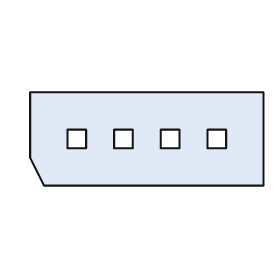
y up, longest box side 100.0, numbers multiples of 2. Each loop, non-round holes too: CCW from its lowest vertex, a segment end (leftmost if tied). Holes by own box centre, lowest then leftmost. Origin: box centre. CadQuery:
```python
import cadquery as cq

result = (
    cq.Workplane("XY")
    .moveTo(-44.0, -20.0)
    .lineTo(50.0, -20.0)
    .lineTo(50.0, 20.0)
    .lineTo(-50.0, 20.0)
    .lineTo(-50.0, -8.0)
    .close()
    .moveTo(-34.0, -4.0)
    .lineTo(-26.0, -4.0)
    .lineTo(-26.0, 4.0)
    .lineTo(-34.0, 4.0)
    .close()
    .moveTo(-14.0, -4.0)
    .lineTo(-6.0, -4.0)
    .lineTo(-6.0, 4.0)
    .lineTo(-14.0, 4.0)
    .close()
    .moveTo(6.0, -4.0)
    .lineTo(14.0, -4.0)
    .lineTo(14.0, 4.0)
    .lineTo(6.0, 4.0)
    .close()
    .moveTo(26.0, -4.0)
    .lineTo(34.0, -4.0)
    .lineTo(34.0, 4.0)
    .lineTo(26.0, 4.0)
    .close()
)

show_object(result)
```